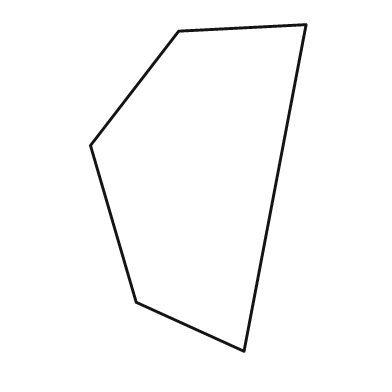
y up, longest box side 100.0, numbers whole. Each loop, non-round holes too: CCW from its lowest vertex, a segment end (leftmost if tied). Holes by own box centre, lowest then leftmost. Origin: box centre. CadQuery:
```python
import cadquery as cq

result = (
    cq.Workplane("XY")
    .moveTo(14.0, -50.0)
    .lineTo(33.0, 50.0)
    .lineTo(-6.0, 48.0)
    .lineTo(-33.0, 13.0)
    .lineTo(-19.0, -35.0)
    .close()
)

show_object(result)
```